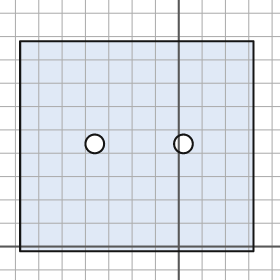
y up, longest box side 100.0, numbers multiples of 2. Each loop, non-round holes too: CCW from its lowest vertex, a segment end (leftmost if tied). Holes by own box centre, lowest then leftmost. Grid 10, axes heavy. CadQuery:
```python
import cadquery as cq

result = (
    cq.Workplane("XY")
    .moveTo(-68.0, -2.0)
    .lineTo(32.0, -2.0)
    .lineTo(32.0, 88.0)
    .lineTo(-68.0, 88.0)
    .close()
    .moveTo(-36.0, 44.0)
    .circle(4.0)
    .moveTo(2.0, 44.0)
    .circle(4.0)
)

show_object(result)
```